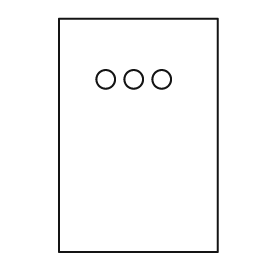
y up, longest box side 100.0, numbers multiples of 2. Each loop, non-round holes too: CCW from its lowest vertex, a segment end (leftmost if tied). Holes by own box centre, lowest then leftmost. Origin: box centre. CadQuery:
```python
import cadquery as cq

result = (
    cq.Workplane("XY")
    .moveTo(-34.0, -50.0)
    .lineTo(34.0, -50.0)
    .lineTo(34.0, 50.0)
    .lineTo(-34.0, 50.0)
    .close()
    .moveTo(-14.0, 24.0)
    .circle(4.0)
    .moveTo(-2.0, 24.0)
    .circle(4.0)
    .moveTo(10.0, 24.0)
    .circle(4.0)
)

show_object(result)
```